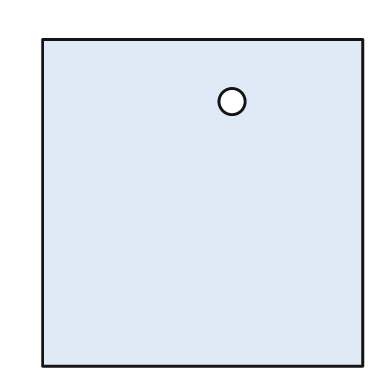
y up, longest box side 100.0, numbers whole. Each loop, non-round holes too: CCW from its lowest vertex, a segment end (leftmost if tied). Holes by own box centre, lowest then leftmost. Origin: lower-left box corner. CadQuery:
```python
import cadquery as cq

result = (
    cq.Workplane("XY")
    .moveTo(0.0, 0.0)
    .lineTo(98.0, 0.0)
    .lineTo(98.0, 100.0)
    .lineTo(0.0, 100.0)
    .close()
    .moveTo(58.0, 81.0)
    .circle(4.0)
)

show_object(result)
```